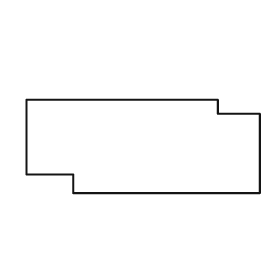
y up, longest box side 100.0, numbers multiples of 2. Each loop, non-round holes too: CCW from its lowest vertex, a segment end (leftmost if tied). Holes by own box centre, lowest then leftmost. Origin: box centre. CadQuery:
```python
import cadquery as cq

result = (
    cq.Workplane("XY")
    .moveTo(-30.0, -20.0)
    .lineTo(50.0, -20.0)
    .lineTo(50.0, 14.0)
    .lineTo(32.0, 14.0)
    .lineTo(32.0, 20.0)
    .lineTo(-50.0, 20.0)
    .lineTo(-50.0, -12.0)
    .lineTo(-30.0, -12.0)
    .close()
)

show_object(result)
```